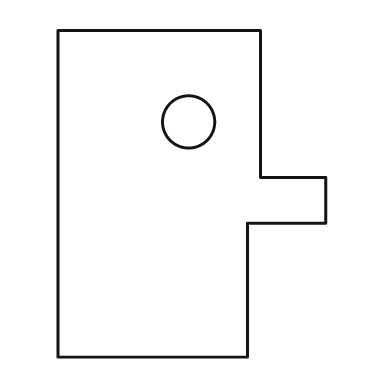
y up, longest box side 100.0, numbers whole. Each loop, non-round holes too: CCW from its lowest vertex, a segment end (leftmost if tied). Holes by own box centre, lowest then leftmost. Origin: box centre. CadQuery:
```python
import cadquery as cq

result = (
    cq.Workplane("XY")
    .moveTo(-41.0, -50.0)
    .lineTo(17.0, -50.0)
    .lineTo(17.0, -9.0)
    .lineTo(41.0, -9.0)
    .lineTo(41.0, 5.0)
    .lineTo(21.0, 5.0)
    .lineTo(21.0, 50.0)
    .lineTo(-41.0, 50.0)
    .close()
    .moveTo(-1.0, 22.0)
    .circle(8.0)
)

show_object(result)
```